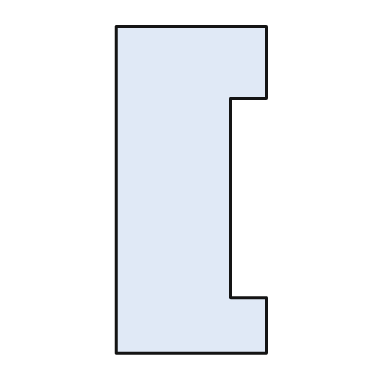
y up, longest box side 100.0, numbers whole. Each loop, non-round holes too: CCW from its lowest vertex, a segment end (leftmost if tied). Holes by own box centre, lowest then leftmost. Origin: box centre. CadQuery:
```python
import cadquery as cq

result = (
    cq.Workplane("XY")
    .moveTo(-23.0, -50.0)
    .lineTo(23.0, -50.0)
    .lineTo(23.0, -33.0)
    .lineTo(12.0, -33.0)
    .lineTo(12.0, 28.0)
    .lineTo(23.0, 28.0)
    .lineTo(23.0, 50.0)
    .lineTo(-23.0, 50.0)
    .close()
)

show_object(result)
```